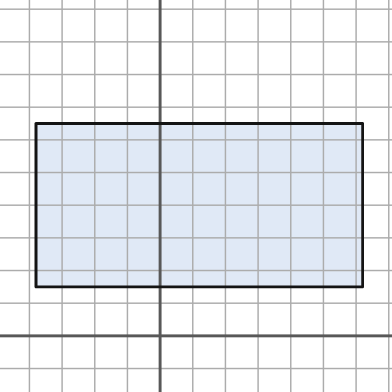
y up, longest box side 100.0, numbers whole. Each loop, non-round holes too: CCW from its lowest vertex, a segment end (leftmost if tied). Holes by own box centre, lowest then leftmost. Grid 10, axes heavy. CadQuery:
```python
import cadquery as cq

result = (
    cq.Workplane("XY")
    .moveTo(-38.0, 15.0)
    .lineTo(62.0, 15.0)
    .lineTo(62.0, 65.0)
    .lineTo(-38.0, 65.0)
    .close()
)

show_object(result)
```